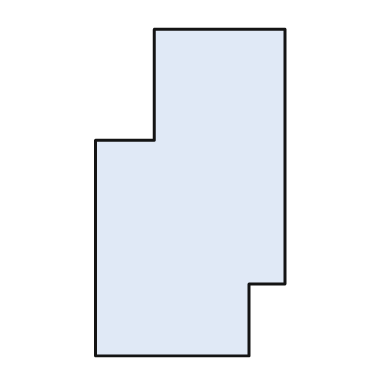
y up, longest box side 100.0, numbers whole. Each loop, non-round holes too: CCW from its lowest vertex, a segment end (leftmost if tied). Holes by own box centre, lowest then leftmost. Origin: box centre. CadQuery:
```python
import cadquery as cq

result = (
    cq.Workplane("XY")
    .moveTo(-29.0, -50.0)
    .lineTo(18.0, -50.0)
    .lineTo(18.0, -28.0)
    .lineTo(29.0, -28.0)
    .lineTo(29.0, 50.0)
    .lineTo(-11.0, 50.0)
    .lineTo(-11.0, 16.0)
    .lineTo(-29.0, 16.0)
    .close()
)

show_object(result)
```